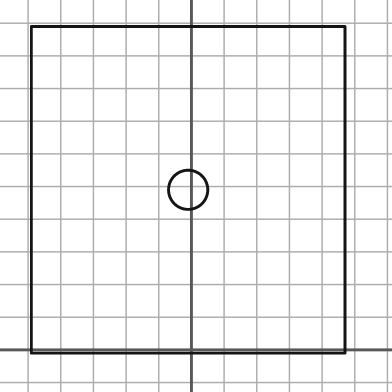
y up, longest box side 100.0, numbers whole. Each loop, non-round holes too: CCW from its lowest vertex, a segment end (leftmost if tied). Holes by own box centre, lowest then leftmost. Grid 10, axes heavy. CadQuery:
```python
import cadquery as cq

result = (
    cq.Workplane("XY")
    .moveTo(-49.0, -1.0)
    .lineTo(47.0, -1.0)
    .lineTo(47.0, 99.0)
    .lineTo(-49.0, 99.0)
    .close()
    .moveTo(-1.0, 49.0)
    .circle(6.0)
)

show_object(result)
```